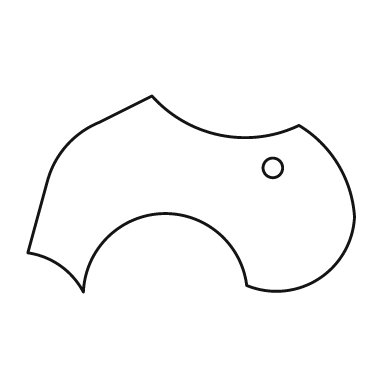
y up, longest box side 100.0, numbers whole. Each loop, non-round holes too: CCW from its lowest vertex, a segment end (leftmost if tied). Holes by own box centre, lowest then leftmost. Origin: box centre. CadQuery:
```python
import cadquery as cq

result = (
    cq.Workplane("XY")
    .moveTo(-33.0, -30.0)
    .threePointArc((-9.0, -6.0), (17.0, -28.0))
    .threePointArc((39.0, -26.0), (50.0, -7.0))
    .threePointArc((45.0, 9.0), (33.0, 21.0))
    .threePointArc((9.0, 18.0), (-12.0, 30.0))
    .lineTo(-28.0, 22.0)
    .threePointArc((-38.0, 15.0), (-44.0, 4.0))
    .lineTo(-50.0, -18.0)
    .threePointArc((-40.0, -22.0), (-33.0, -30.0))
    .close()
    .moveTo(25.0, 8.0)
    .circle(3.0)
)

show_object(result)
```